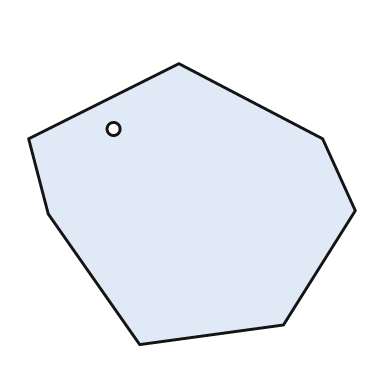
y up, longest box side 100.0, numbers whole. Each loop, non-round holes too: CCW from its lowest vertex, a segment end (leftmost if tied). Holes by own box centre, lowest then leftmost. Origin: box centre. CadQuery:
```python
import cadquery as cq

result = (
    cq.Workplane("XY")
    .moveTo(-16.0, -43.0)
    .lineTo(28.0, -37.0)
    .lineTo(50.0, -2.0)
    .lineTo(40.0, 20.0)
    .lineTo(-4.0, 43.0)
    .lineTo(-50.0, 20.0)
    .lineTo(-44.0, -3.0)
    .close()
    .moveTo(-24.0, 23.0)
    .circle(2.0)
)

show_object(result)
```